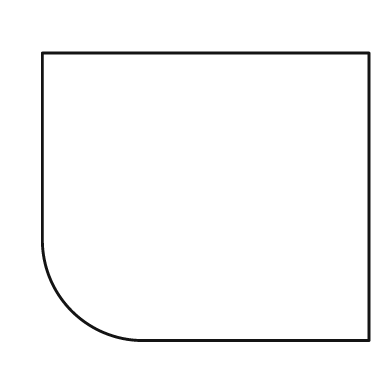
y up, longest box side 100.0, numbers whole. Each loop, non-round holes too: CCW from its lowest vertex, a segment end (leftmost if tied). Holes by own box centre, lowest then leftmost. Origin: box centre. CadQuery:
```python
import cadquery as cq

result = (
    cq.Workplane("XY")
    .moveTo(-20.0, -44.0)
    .lineTo(50.0, -44.0)
    .lineTo(50.0, 44.0)
    .lineTo(-50.0, 44.0)
    .lineTo(-50.0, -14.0)
    .threePointArc((-41.0, -35.0), (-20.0, -44.0))
    .close()
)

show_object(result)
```